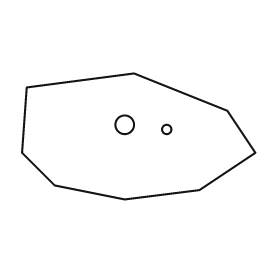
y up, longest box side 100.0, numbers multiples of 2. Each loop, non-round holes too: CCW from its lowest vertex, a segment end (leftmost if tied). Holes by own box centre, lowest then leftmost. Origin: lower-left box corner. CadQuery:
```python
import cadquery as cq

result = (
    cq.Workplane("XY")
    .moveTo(44.0, 0.0)
    .lineTo(76.0, 4.0)
    .lineTo(100.0, 20.0)
    .lineTo(88.0, 38.0)
    .lineTo(48.0, 54.0)
    .lineTo(2.0, 48.0)
    .lineTo(0.0, 20.0)
    .lineTo(14.0, 6.0)
    .close()
    .moveTo(62.0, 30.0)
    .circle(2.0)
    .moveTo(44.0, 32.0)
    .circle(4.0)
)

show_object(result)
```